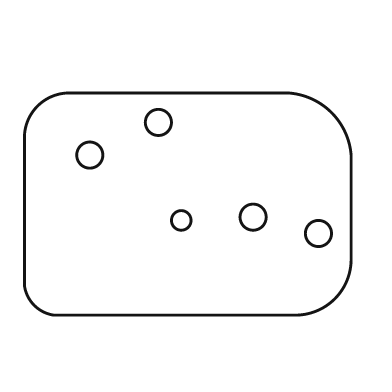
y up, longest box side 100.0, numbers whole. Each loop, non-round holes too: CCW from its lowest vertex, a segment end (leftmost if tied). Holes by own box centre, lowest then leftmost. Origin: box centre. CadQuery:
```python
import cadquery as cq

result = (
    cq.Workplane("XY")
    .moveTo(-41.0, -34.0)
    .lineTo(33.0, -34.0)
    .threePointArc((45.0, -29.0), (50.0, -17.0))
    .lineTo(50.0, 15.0)
    .threePointArc((44.0, 28.0), (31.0, 34.0))
    .lineTo(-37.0, 34.0)
    .threePointArc((-46.0, 30.0), (-50.0, 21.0))
    .lineTo(-50.0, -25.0)
    .threePointArc((-47.0, -31.0), (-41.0, -34.0))
    .close()
    .moveTo(40.0, -9.0)
    .circle(4.0)
    .moveTo(-2.0, -5.0)
    .circle(3.0)
    .moveTo(20.0, -4.0)
    .circle(4.0)
    .moveTo(-30.0, 15.0)
    .circle(4.0)
    .moveTo(-9.0, 25.0)
    .circle(4.0)
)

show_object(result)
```